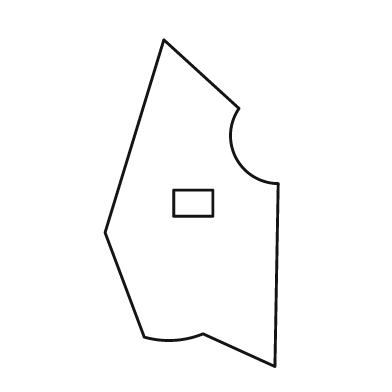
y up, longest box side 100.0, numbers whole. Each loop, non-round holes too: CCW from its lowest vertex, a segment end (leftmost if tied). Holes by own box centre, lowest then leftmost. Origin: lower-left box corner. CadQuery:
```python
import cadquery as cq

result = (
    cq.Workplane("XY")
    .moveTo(52.0, 0.0)
    .lineTo(53.0, 56.0)
    .threePointArc((40.0, 64.0), (41.0, 79.0))
    .lineTo(18.0, 100.0)
    .lineTo(0.0, 41.0)
    .lineTo(12.0, 9.0)
    .threePointArc((21.0, 8.0), (30.0, 10.0))
    .close()
    .moveTo(21.0, 46.0)
    .lineTo(33.0, 46.0)
    .lineTo(33.0, 54.0)
    .lineTo(21.0, 54.0)
    .close()
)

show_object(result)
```